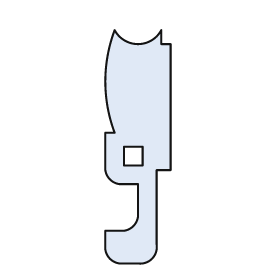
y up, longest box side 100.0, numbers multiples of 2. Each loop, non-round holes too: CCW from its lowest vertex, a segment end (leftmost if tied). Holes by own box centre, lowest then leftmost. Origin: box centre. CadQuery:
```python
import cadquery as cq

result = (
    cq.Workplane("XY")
    .moveTo(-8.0, -50.0)
    .lineTo(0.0, -50.0)
    .threePointArc((6.0, -48.0), (8.0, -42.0))
    .lineTo(8.0, -10.0)
    .lineTo(14.0, -10.0)
    .lineTo(14.0, 44.0)
    .lineTo(10.0, 44.0)
    .lineTo(10.0, 50.0)
    .threePointArc((0.0, 44.0), (-10.0, 50.0))
    .threePointArc((-14.0, 28.0), (-10.0, 6.0))
    .lineTo(-14.0, 6.0)
    .lineTo(-14.0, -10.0)
    .threePointArc((-12.0, -14.0), (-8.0, -16.0))
    .lineTo(0.0, -16.0)
    .lineTo(0.0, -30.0)
    .threePointArc((-2.0, -34.0), (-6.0, -36.0))
    .lineTo(-14.0, -36.0)
    .lineTo(-14.0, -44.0)
    .threePointArc((-12.0, -48.0), (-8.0, -50.0))
    .close()
    .moveTo(-6.0, -8.0)
    .lineTo(2.0, -8.0)
    .lineTo(2.0, 0.0)
    .lineTo(-6.0, 0.0)
    .close()
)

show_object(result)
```